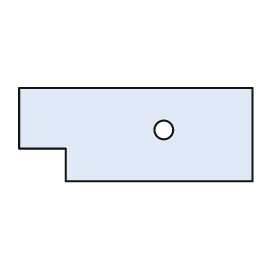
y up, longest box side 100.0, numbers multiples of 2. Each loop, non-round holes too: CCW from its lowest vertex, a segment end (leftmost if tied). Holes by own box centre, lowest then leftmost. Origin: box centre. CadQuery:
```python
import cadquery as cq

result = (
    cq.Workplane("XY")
    .moveTo(-30.0, -20.0)
    .lineTo(50.0, -20.0)
    .lineTo(50.0, 20.0)
    .lineTo(-50.0, 20.0)
    .lineTo(-50.0, -6.0)
    .lineTo(-30.0, -6.0)
    .close()
    .moveTo(12.0, 2.0)
    .circle(4.0)
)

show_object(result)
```